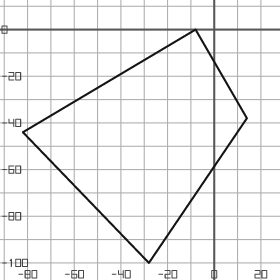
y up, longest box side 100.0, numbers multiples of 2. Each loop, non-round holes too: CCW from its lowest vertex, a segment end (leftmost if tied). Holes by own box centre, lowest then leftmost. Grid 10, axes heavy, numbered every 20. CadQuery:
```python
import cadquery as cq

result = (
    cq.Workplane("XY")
    .moveTo(-28.0, -100.0)
    .lineTo(14.0, -38.0)
    .lineTo(-8.0, 0.0)
    .lineTo(-82.0, -44.0)
    .close()
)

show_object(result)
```